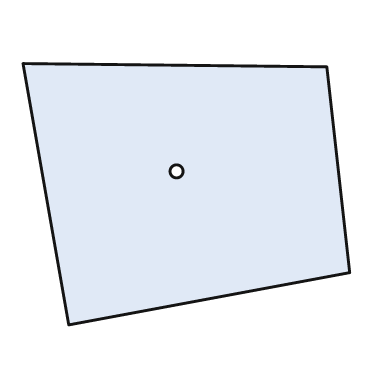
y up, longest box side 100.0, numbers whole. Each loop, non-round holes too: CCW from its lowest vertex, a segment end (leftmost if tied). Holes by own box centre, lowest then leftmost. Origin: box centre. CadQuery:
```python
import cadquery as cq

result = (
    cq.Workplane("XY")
    .moveTo(-36.0, -40.0)
    .lineTo(50.0, -24.0)
    .lineTo(43.0, 39.0)
    .lineTo(-50.0, 40.0)
    .close()
    .moveTo(-3.0, 7.0)
    .circle(2.0)
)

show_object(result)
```